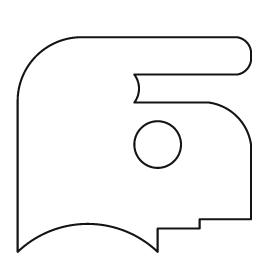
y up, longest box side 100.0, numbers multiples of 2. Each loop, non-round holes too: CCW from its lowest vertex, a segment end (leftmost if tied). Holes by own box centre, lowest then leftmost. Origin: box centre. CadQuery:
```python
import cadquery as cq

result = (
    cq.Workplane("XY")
    .moveTo(-50.0, -46.0)
    .threePointArc((-20.0, -34.0), (10.0, -46.0))
    .lineTo(10.0, -36.0)
    .lineTo(28.0, -36.0)
    .lineTo(28.0, -32.0)
    .lineTo(50.0, -32.0)
    .lineTo(50.0, 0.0)
    .threePointArc((44.0, 12.0), (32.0, 18.0))
    .lineTo(0.0, 18.0)
    .threePointArc((2.0, 24.0), (0.0, 30.0))
    .lineTo(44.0, 30.0)
    .threePointArc((48.0, 32.0), (50.0, 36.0))
    .lineTo(50.0, 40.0)
    .threePointArc((48.0, 44.0), (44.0, 46.0))
    .lineTo(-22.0, 46.0)
    .threePointArc((-42.0, 38.0), (-50.0, 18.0))
    .close()
    .moveTo(10.0, 0.0)
    .circle(10.0)
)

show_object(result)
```